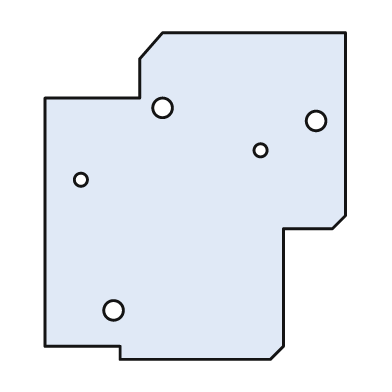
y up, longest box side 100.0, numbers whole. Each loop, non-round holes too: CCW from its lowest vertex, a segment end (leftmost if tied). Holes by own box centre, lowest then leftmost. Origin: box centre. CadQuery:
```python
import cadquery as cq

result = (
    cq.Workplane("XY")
    .moveTo(-23.0, -50.0)
    .lineTo(23.0, -50.0)
    .lineTo(27.0, -46.0)
    .lineTo(27.0, -10.0)
    .lineTo(42.0, -10.0)
    .lineTo(46.0, -6.0)
    .lineTo(46.0, 50.0)
    .lineTo(-10.0, 50.0)
    .lineTo(-17.0, 42.0)
    .lineTo(-17.0, 30.0)
    .lineTo(-46.0, 30.0)
    .lineTo(-46.0, -46.0)
    .lineTo(-23.0, -46.0)
    .close()
    .moveTo(-25.0, -35.0)
    .circle(3.0)
    .moveTo(-35.0, 5.0)
    .circle(2.0)
    .moveTo(20.0, 14.0)
    .circle(2.0)
    .moveTo(37.0, 23.0)
    .circle(3.0)
    .moveTo(-10.0, 27.0)
    .circle(3.0)
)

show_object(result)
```